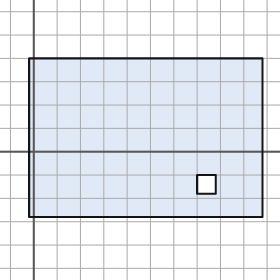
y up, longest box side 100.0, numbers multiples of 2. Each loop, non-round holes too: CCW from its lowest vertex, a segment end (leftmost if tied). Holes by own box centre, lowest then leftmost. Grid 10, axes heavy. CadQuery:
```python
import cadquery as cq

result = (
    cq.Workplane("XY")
    .moveTo(-2.0, -28.0)
    .lineTo(98.0, -28.0)
    .lineTo(98.0, 40.0)
    .lineTo(-2.0, 40.0)
    .close()
    .moveTo(70.0, -18.0)
    .lineTo(78.0, -18.0)
    .lineTo(78.0, -10.0)
    .lineTo(70.0, -10.0)
    .close()
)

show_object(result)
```